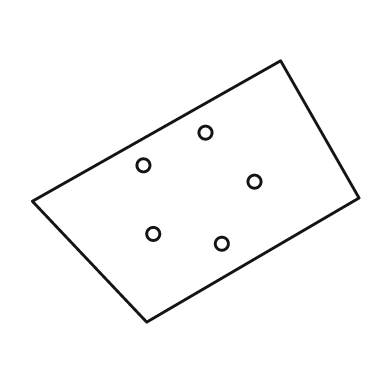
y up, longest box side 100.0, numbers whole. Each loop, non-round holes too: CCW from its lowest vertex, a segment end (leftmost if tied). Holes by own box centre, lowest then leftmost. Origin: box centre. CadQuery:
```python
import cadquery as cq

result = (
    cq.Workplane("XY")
    .moveTo(-15.0, -40.0)
    .lineTo(50.0, -2.0)
    .lineTo(26.0, 40.0)
    .lineTo(-50.0, -3.0)
    .close()
    .moveTo(8.0, -16.0)
    .circle(2.0)
    .moveTo(-13.0, -13.0)
    .circle(2.0)
    .moveTo(18.0, 3.0)
    .circle(2.0)
    .moveTo(-16.0, 8.0)
    .circle(2.0)
    .moveTo(3.0, 18.0)
    .circle(2.0)
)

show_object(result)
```